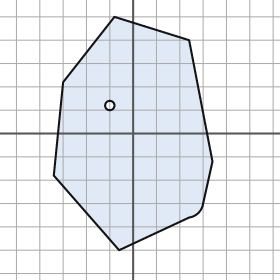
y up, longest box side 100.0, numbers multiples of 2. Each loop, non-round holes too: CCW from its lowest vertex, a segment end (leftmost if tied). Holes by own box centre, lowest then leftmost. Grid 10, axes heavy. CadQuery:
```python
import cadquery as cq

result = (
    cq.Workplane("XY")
    .moveTo(-6.0, -50.0)
    .lineTo(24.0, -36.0)
    .threePointArc((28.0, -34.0), (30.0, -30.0))
    .lineTo(34.0, -12.0)
    .lineTo(24.0, 40.0)
    .lineTo(-8.0, 50.0)
    .lineTo(-30.0, 22.0)
    .lineTo(-34.0, -18.0)
    .close()
    .moveTo(-10.0, 12.0)
    .circle(2.0)
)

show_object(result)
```